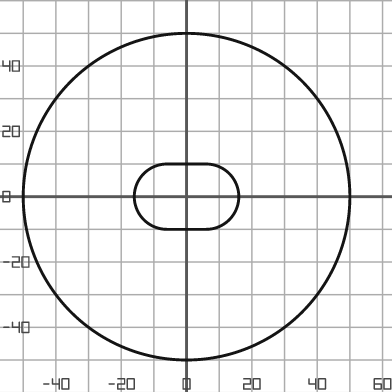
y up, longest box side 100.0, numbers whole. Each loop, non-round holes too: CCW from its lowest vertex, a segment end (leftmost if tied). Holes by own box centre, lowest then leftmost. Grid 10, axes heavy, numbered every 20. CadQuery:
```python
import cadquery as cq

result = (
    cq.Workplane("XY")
    .moveTo(0.0, 0.0)
    .circle(50.0)
    .moveTo(-6.0, -10.0)
    .lineTo(6.0, -10.0)
    .threePointArc((16.0, 0.0), (6.0, 10.0))
    .lineTo(-6.0, 10.0)
    .threePointArc((-16.0, 0.0), (-6.0, -10.0))
    .close()
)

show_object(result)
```